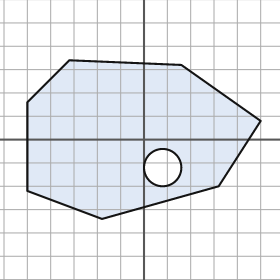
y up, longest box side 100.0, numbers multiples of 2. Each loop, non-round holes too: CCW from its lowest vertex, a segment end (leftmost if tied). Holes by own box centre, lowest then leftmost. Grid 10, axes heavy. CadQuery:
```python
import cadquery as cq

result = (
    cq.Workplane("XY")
    .moveTo(-18.0, -34.0)
    .lineTo(32.0, -20.0)
    .lineTo(50.0, 8.0)
    .lineTo(16.0, 32.0)
    .lineTo(-32.0, 34.0)
    .lineTo(-50.0, 16.0)
    .lineTo(-50.0, -22.0)
    .close()
    .moveTo(8.0, -12.0)
    .circle(8.0)
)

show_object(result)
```